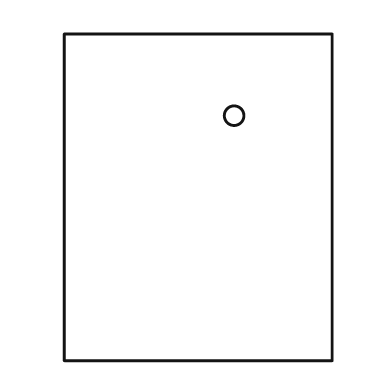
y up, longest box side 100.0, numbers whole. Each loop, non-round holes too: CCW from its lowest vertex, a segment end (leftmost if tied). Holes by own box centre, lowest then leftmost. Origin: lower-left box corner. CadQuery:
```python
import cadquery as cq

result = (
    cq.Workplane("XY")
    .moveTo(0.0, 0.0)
    .lineTo(82.0, 0.0)
    .lineTo(82.0, 100.0)
    .lineTo(0.0, 100.0)
    .close()
    .moveTo(52.0, 75.0)
    .circle(3.0)
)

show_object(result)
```